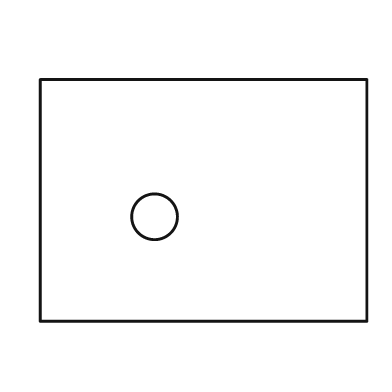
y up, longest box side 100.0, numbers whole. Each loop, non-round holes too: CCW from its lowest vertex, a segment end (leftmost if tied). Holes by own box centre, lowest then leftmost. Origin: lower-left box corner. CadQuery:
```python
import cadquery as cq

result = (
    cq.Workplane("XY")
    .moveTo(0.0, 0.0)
    .lineTo(100.0, 0.0)
    .lineTo(100.0, 74.0)
    .lineTo(0.0, 74.0)
    .close()
    .moveTo(35.0, 32.0)
    .circle(7.0)
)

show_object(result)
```